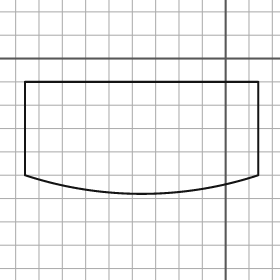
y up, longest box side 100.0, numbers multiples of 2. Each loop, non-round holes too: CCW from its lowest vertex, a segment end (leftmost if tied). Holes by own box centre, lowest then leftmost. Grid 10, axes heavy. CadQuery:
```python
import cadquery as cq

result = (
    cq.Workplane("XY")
    .moveTo(-86.0, -50.0)
    .threePointArc((-36.0, -58.0), (14.0, -50.0))
    .lineTo(14.0, -10.0)
    .lineTo(-86.0, -10.0)
    .close()
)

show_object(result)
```